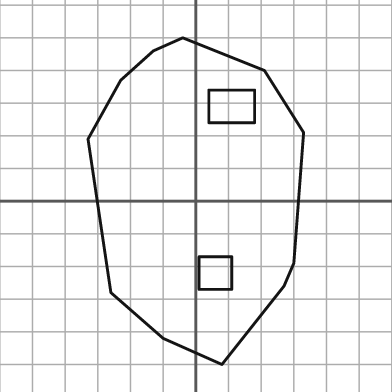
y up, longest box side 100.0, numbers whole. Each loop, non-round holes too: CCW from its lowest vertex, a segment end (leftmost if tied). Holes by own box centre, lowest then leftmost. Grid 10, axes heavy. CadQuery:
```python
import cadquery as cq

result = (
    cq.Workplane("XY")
    .moveTo(8.0, -50.0)
    .lineTo(27.0, -26.0)
    .lineTo(30.0, -19.0)
    .lineTo(33.0, 21.0)
    .lineTo(21.0, 40.0)
    .lineTo(-4.0, 50.0)
    .lineTo(-13.0, 46.0)
    .lineTo(-23.0, 37.0)
    .lineTo(-33.0, 19.0)
    .lineTo(-26.0, -28.0)
    .lineTo(-10.0, -42.0)
    .close()
    .moveTo(1.0, -27.0)
    .lineTo(11.0, -27.0)
    .lineTo(11.0, -17.0)
    .lineTo(1.0, -17.0)
    .close()
    .moveTo(4.0, 24.0)
    .lineTo(18.0, 24.0)
    .lineTo(18.0, 34.0)
    .lineTo(4.0, 34.0)
    .close()
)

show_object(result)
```